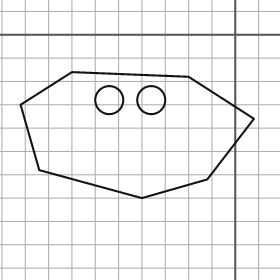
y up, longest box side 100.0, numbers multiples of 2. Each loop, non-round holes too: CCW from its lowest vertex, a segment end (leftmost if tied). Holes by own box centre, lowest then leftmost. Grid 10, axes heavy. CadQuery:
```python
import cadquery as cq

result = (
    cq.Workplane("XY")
    .moveTo(-40.0, -70.0)
    .lineTo(-12.0, -62.0)
    .lineTo(8.0, -36.0)
    .lineTo(-20.0, -18.0)
    .lineTo(-70.0, -16.0)
    .lineTo(-92.0, -30.0)
    .lineTo(-84.0, -58.0)
    .close()
    .moveTo(-54.0, -28.0)
    .circle(6.0)
    .moveTo(-36.0, -28.0)
    .circle(6.0)
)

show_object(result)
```